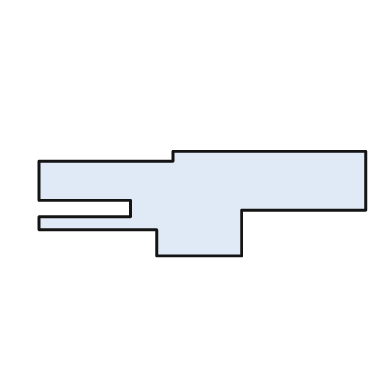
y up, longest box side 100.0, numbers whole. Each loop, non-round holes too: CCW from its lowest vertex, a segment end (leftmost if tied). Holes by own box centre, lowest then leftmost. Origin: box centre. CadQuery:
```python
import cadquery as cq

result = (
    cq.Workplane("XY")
    .moveTo(-14.0, -16.0)
    .lineTo(12.0, -16.0)
    .lineTo(12.0, -2.0)
    .lineTo(50.0, -2.0)
    .lineTo(50.0, 16.0)
    .lineTo(-9.0, 16.0)
    .lineTo(-9.0, 13.0)
    .lineTo(-50.0, 13.0)
    .lineTo(-50.0, 1.0)
    .lineTo(-22.0, 1.0)
    .lineTo(-22.0, -4.0)
    .lineTo(-50.0, -4.0)
    .lineTo(-50.0, -8.0)
    .lineTo(-14.0, -8.0)
    .close()
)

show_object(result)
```